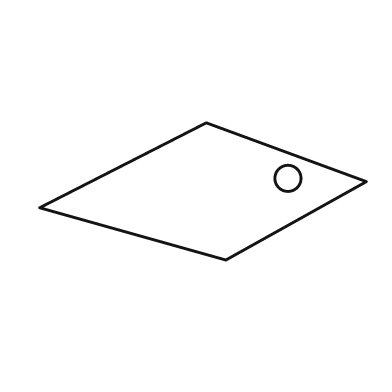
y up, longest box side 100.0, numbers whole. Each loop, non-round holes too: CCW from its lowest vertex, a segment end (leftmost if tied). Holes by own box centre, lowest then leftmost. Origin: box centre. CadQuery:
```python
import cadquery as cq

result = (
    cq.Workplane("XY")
    .moveTo(7.0, -21.0)
    .lineTo(50.0, 3.0)
    .lineTo(1.0, 21.0)
    .lineTo(-50.0, -5.0)
    .close()
    .moveTo(26.0, 4.0)
    .circle(4.0)
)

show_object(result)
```